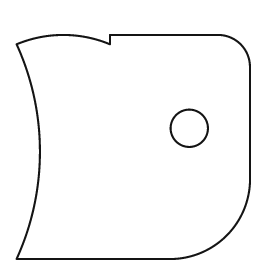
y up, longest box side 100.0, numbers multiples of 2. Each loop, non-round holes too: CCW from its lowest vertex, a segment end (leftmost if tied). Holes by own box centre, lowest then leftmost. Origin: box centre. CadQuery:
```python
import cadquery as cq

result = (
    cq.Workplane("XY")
    .moveTo(-50.0, -48.0)
    .lineTo(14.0, -48.0)
    .threePointArc((40.0, -38.0), (50.0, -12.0))
    .lineTo(50.0, 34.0)
    .threePointArc((46.0, 44.0), (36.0, 48.0))
    .lineTo(-10.0, 48.0)
    .lineTo(-10.0, 44.0)
    .threePointArc((-30.0, 48.0), (-50.0, 44.0))
    .threePointArc((-40.0, -2.0), (-50.0, -48.0))
    .close()
    .moveTo(24.0, 8.0)
    .circle(8.0)
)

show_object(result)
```